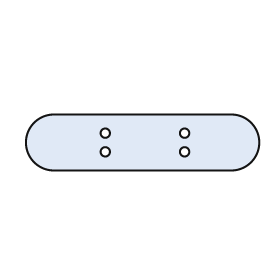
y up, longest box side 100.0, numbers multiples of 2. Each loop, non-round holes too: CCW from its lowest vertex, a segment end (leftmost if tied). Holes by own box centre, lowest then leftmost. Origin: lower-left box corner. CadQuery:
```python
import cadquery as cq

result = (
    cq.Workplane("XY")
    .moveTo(12.0, 0.0)
    .lineTo(88.0, 0.0)
    .threePointArc((100.0, 12.0), (88.0, 24.0))
    .lineTo(12.0, 24.0)
    .threePointArc((0.0, 12.0), (12.0, 0.0))
    .close()
    .moveTo(34.0, 8.0)
    .circle(2.0)
    .moveTo(68.0, 8.0)
    .circle(2.0)
    .moveTo(34.0, 16.0)
    .circle(2.0)
    .moveTo(68.0, 16.0)
    .circle(2.0)
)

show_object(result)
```